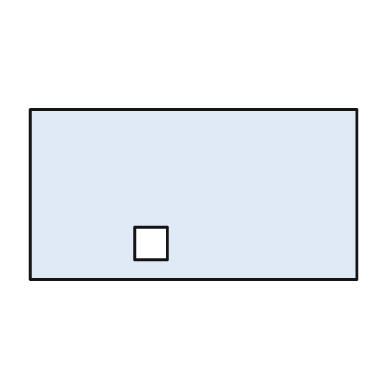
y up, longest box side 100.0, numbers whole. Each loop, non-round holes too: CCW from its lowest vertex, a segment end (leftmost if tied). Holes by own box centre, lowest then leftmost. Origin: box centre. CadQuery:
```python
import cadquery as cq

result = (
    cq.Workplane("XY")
    .moveTo(-50.0, -26.0)
    .lineTo(50.0, -26.0)
    .lineTo(50.0, 26.0)
    .lineTo(-50.0, 26.0)
    .close()
    .moveTo(-18.0, -20.0)
    .lineTo(-8.0, -20.0)
    .lineTo(-8.0, -10.0)
    .lineTo(-18.0, -10.0)
    .close()
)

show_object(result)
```